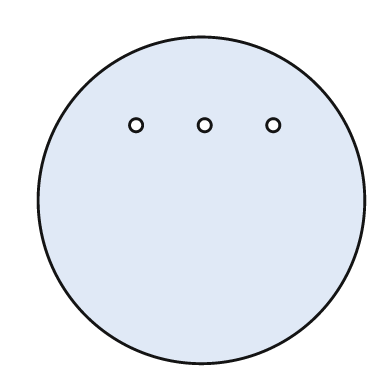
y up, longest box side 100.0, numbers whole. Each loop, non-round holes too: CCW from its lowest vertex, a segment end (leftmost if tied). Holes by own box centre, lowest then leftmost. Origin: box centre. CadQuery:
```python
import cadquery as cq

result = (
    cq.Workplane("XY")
    .moveTo(0.0, 0.0)
    .circle(50.0)
    .moveTo(-20.0, 23.0)
    .circle(2.0)
    .moveTo(1.0, 23.0)
    .circle(2.0)
    .moveTo(22.0, 23.0)
    .circle(2.0)
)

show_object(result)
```